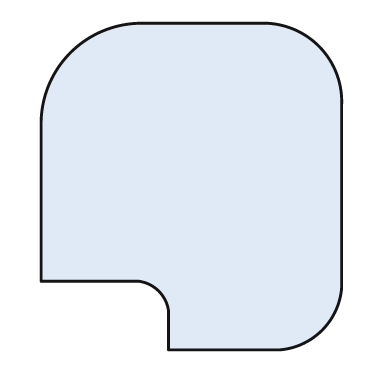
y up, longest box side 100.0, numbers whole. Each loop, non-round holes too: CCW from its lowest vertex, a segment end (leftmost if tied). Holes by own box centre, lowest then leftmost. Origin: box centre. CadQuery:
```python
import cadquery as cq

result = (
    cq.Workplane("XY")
    .moveTo(-7.0, -50.0)
    .lineTo(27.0, -50.0)
    .threePointArc((40.0, -44.0), (46.0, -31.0))
    .lineTo(46.0, 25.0)
    .threePointArc((39.0, 43.0), (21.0, 50.0))
    .lineTo(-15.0, 50.0)
    .threePointArc((-37.0, 41.0), (-46.0, 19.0))
    .lineTo(-46.0, -29.0)
    .lineTo(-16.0, -29.0)
    .threePointArc((-10.0, -32.0), (-7.0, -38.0))
    .close()
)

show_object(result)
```